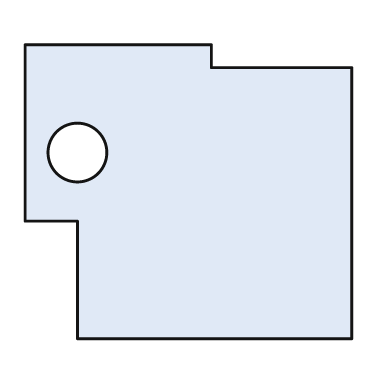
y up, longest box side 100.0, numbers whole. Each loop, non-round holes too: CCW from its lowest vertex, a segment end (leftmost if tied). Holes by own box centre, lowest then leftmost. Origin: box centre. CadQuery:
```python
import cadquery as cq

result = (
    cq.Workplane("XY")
    .moveTo(-34.0, -45.0)
    .lineTo(50.0, -45.0)
    .lineTo(50.0, 38.0)
    .lineTo(7.0, 38.0)
    .lineTo(7.0, 45.0)
    .lineTo(-50.0, 45.0)
    .lineTo(-50.0, -9.0)
    .lineTo(-34.0, -9.0)
    .close()
    .moveTo(-34.0, 12.0)
    .circle(9.0)
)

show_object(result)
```